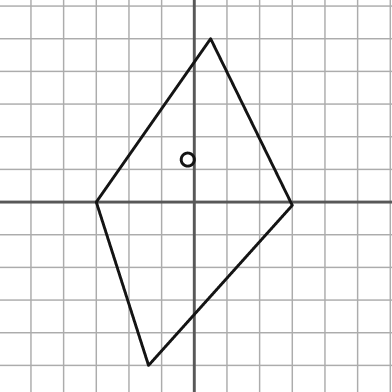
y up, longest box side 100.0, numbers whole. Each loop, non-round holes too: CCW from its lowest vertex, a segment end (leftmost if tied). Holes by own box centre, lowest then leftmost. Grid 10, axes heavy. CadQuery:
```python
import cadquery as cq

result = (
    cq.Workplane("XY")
    .moveTo(-14.0, -50.0)
    .lineTo(30.0, -1.0)
    .lineTo(5.0, 50.0)
    .lineTo(-30.0, 0.0)
    .close()
    .moveTo(-2.0, 13.0)
    .circle(2.0)
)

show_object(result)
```